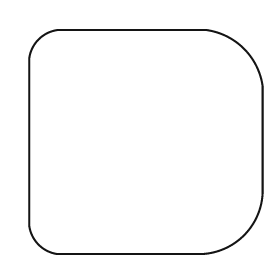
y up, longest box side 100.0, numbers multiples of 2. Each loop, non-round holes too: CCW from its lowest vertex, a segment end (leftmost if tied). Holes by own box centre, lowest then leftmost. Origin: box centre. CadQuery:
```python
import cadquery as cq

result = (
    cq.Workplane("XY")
    .moveTo(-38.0, -48.0)
    .lineTo(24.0, -48.0)
    .threePointArc((42.0, -40.0), (50.0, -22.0))
    .lineTo(50.0, 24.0)
    .threePointArc((42.0, 40.0), (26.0, 48.0))
    .lineTo(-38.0, 48.0)
    .threePointArc((-46.0, 44.0), (-50.0, 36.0))
    .lineTo(-50.0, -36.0)
    .threePointArc((-46.0, -44.0), (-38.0, -48.0))
    .close()
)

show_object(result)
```